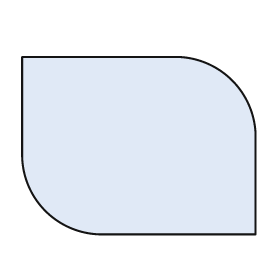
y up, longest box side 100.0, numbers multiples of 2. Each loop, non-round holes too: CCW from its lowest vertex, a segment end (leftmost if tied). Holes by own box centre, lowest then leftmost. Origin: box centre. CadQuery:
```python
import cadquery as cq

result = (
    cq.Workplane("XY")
    .moveTo(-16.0, -38.0)
    .lineTo(50.0, -38.0)
    .lineTo(50.0, 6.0)
    .threePointArc((40.0, 28.0), (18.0, 38.0))
    .lineTo(-50.0, 38.0)
    .lineTo(-50.0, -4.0)
    .threePointArc((-40.0, -28.0), (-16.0, -38.0))
    .close()
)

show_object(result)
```